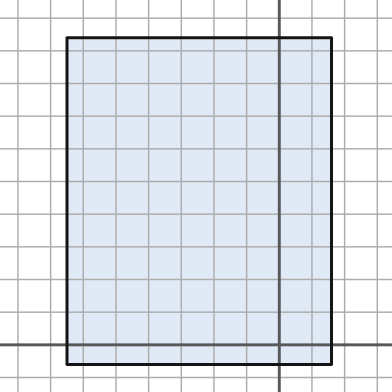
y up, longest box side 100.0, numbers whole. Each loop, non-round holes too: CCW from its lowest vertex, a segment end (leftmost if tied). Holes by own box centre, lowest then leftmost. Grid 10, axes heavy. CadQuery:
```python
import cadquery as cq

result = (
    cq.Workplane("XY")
    .moveTo(-65.0, -6.0)
    .lineTo(16.0, -6.0)
    .lineTo(16.0, 94.0)
    .lineTo(-65.0, 94.0)
    .close()
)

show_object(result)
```